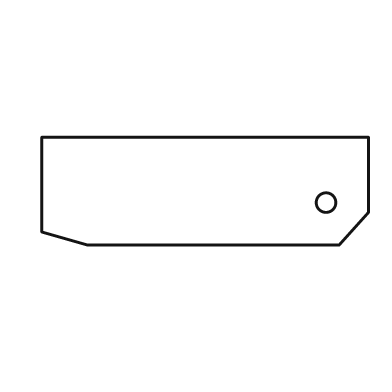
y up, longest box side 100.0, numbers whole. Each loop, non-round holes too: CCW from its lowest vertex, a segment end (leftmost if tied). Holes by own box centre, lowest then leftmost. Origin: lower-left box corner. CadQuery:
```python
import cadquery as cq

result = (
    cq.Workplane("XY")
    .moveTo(14.0, 0.0)
    .lineTo(91.0, 0.0)
    .lineTo(100.0, 10.0)
    .lineTo(100.0, 33.0)
    .lineTo(0.0, 33.0)
    .lineTo(0.0, 4.0)
    .close()
    .moveTo(87.0, 13.0)
    .circle(3.0)
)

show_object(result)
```